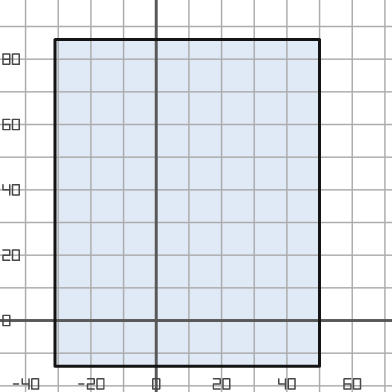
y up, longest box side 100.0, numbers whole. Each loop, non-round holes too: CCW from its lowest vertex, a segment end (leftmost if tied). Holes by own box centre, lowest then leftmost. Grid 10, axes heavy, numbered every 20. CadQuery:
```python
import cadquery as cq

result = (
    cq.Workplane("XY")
    .moveTo(-31.0, -14.0)
    .lineTo(50.0, -14.0)
    .lineTo(50.0, 86.0)
    .lineTo(-31.0, 86.0)
    .close()
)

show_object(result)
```